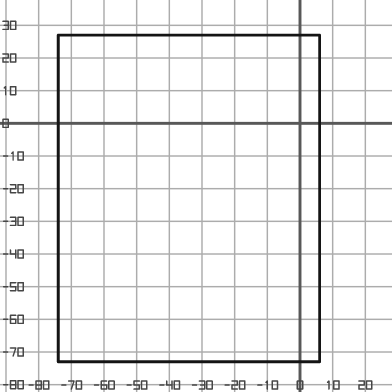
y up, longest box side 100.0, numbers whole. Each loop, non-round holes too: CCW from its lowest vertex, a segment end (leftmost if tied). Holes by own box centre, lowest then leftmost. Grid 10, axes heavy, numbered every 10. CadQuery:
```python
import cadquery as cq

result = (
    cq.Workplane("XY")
    .moveTo(-74.0, -73.0)
    .lineTo(6.0, -73.0)
    .lineTo(6.0, 27.0)
    .lineTo(-74.0, 27.0)
    .close()
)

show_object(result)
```